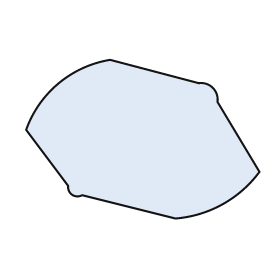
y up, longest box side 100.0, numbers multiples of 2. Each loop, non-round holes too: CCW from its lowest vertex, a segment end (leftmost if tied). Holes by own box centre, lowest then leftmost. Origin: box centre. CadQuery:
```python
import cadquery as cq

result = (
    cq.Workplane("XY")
    .moveTo(14.0, -34.0)
    .threePointArc((34.0, -28.0), (50.0, -14.0))
    .lineTo(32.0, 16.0)
    .threePointArc((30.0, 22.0), (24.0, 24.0))
    .lineTo(-14.0, 34.0)
    .threePointArc((-36.0, 24.0), (-50.0, 4.0))
    .lineTo(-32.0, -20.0)
    .threePointArc((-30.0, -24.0), (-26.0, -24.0))
    .close()
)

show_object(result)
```